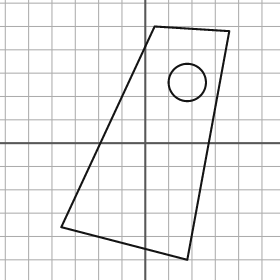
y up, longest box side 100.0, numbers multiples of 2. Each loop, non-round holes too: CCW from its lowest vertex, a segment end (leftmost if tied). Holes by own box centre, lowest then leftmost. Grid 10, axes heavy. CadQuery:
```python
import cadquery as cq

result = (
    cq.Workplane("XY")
    .moveTo(18.0, -50.0)
    .lineTo(36.0, 48.0)
    .lineTo(4.0, 50.0)
    .lineTo(-36.0, -36.0)
    .close()
    .moveTo(18.0, 26.0)
    .circle(8.0)
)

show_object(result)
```